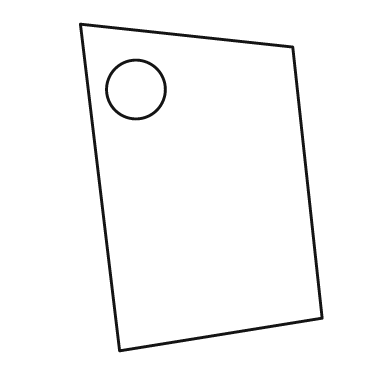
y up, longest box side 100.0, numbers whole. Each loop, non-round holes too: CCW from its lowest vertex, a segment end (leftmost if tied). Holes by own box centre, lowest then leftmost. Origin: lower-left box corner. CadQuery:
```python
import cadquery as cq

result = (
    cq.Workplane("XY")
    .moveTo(12.0, 0.0)
    .lineTo(74.0, 10.0)
    .lineTo(65.0, 93.0)
    .lineTo(0.0, 100.0)
    .close()
    .moveTo(17.0, 80.0)
    .circle(9.0)
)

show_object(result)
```